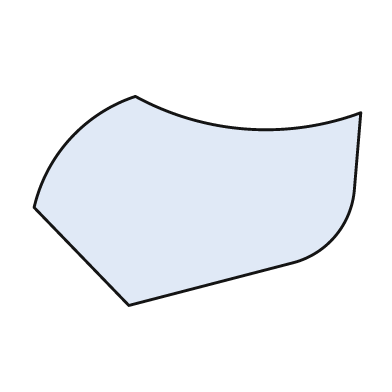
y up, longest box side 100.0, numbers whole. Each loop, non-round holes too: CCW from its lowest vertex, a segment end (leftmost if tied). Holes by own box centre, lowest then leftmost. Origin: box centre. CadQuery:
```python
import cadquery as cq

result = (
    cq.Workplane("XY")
    .moveTo(-21.0, -32.0)
    .lineTo(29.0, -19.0)
    .threePointArc((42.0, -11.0), (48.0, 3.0))
    .lineTo(50.0, 27.0)
    .threePointArc((15.0, 22.0), (-19.0, 32.0))
    .threePointArc((-39.0, 19.0), (-50.0, -2.0))
    .close()
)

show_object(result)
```